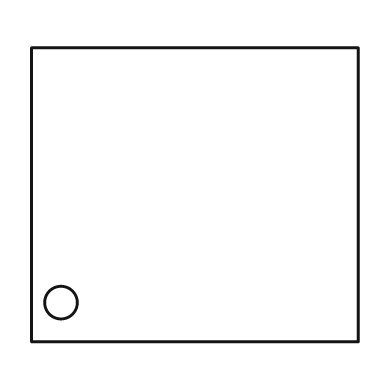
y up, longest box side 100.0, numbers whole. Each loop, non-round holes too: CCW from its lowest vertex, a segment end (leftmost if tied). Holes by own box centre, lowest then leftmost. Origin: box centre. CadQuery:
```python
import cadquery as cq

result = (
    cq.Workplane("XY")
    .moveTo(-50.0, -45.0)
    .lineTo(50.0, -45.0)
    .lineTo(50.0, 45.0)
    .lineTo(-50.0, 45.0)
    .close()
    .moveTo(-41.0, -33.0)
    .circle(5.0)
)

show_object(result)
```